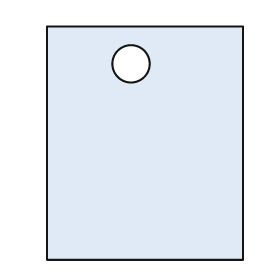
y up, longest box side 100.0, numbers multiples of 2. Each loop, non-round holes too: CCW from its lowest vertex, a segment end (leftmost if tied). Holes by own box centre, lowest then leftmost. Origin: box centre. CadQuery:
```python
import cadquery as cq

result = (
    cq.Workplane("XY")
    .moveTo(-42.0, -50.0)
    .lineTo(42.0, -50.0)
    .lineTo(42.0, 50.0)
    .lineTo(-42.0, 50.0)
    .close()
    .moveTo(-6.0, 34.0)
    .circle(8.0)
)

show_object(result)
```